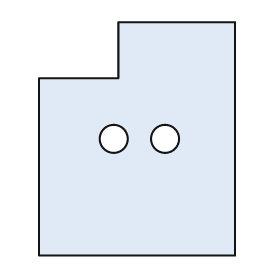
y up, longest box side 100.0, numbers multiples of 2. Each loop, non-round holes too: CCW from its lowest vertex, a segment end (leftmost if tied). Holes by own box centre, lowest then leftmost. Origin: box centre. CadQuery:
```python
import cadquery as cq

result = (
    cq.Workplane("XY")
    .moveTo(-42.0, -50.0)
    .lineTo(42.0, -50.0)
    .lineTo(42.0, 50.0)
    .lineTo(-8.0, 50.0)
    .lineTo(-8.0, 26.0)
    .lineTo(-42.0, 26.0)
    .close()
    .moveTo(-10.0, 0.0)
    .circle(6.0)
    .moveTo(12.0, 0.0)
    .circle(6.0)
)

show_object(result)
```